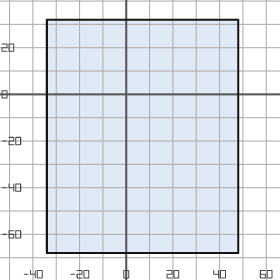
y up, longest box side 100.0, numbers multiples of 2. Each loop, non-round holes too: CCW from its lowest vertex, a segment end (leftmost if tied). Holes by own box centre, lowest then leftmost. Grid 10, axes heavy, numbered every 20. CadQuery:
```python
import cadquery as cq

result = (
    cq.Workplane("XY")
    .moveTo(-34.0, -68.0)
    .lineTo(48.0, -68.0)
    .lineTo(48.0, 32.0)
    .lineTo(-34.0, 32.0)
    .close()
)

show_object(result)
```